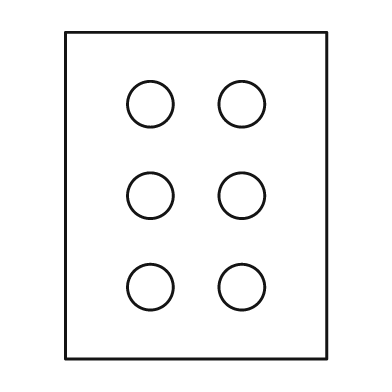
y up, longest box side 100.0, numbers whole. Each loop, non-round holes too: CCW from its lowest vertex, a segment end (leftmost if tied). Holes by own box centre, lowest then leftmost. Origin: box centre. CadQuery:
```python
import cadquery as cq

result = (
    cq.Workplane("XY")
    .moveTo(-40.0, -50.0)
    .lineTo(40.0, -50.0)
    .lineTo(40.0, 50.0)
    .lineTo(-40.0, 50.0)
    .close()
    .moveTo(-14.0, -28.0)
    .circle(7.0)
    .moveTo(14.0, -28.0)
    .circle(7.0)
    .moveTo(-14.0, 0.0)
    .circle(7.0)
    .moveTo(14.0, 0.0)
    .circle(7.0)
    .moveTo(-14.0, 28.0)
    .circle(7.0)
    .moveTo(14.0, 28.0)
    .circle(7.0)
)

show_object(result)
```